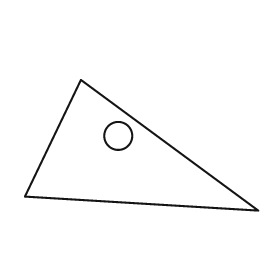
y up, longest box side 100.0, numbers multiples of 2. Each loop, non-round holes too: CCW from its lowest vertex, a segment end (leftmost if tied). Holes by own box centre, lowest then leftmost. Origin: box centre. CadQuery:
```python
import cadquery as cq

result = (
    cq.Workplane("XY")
    .moveTo(50.0, -28.0)
    .lineTo(-26.0, 28.0)
    .lineTo(-50.0, -22.0)
    .close()
    .moveTo(-10.0, 4.0)
    .circle(6.0)
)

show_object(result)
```